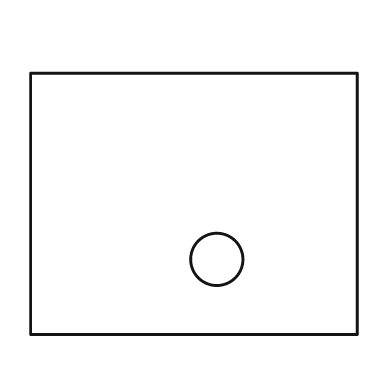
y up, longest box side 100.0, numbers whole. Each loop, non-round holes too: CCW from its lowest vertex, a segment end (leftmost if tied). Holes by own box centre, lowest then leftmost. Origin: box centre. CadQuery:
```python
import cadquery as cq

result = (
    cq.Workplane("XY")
    .moveTo(-50.0, -40.0)
    .lineTo(50.0, -40.0)
    .lineTo(50.0, 40.0)
    .lineTo(-50.0, 40.0)
    .close()
    .moveTo(7.0, -17.0)
    .circle(8.0)
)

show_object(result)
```